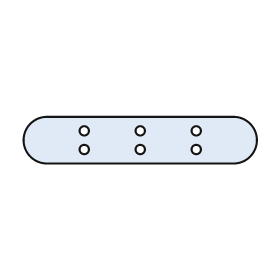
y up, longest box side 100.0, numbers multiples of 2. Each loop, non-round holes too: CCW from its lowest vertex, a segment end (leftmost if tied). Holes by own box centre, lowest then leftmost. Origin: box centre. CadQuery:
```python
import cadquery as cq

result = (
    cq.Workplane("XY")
    .moveTo(-40.0, -10.0)
    .lineTo(40.0, -10.0)
    .threePointArc((50.0, 0.0), (40.0, 10.0))
    .lineTo(-40.0, 10.0)
    .threePointArc((-50.0, 0.0), (-40.0, -10.0))
    .close()
    .moveTo(-24.0, -4.0)
    .circle(2.0)
    .moveTo(0.0, -4.0)
    .circle(2.0)
    .moveTo(24.0, -4.0)
    .circle(2.0)
    .moveTo(-24.0, 4.0)
    .circle(2.0)
    .moveTo(0.0, 4.0)
    .circle(2.0)
    .moveTo(24.0, 4.0)
    .circle(2.0)
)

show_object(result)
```